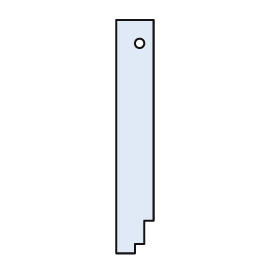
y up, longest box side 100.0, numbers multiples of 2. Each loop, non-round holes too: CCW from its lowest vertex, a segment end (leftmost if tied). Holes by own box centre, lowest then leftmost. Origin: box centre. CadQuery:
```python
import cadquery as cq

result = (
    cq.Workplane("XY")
    .moveTo(-8.0, -50.0)
    .lineTo(0.0, -50.0)
    .lineTo(0.0, -46.0)
    .lineTo(4.0, -46.0)
    .lineTo(4.0, -36.0)
    .lineTo(8.0, -36.0)
    .lineTo(8.0, 50.0)
    .lineTo(-8.0, 50.0)
    .close()
    .moveTo(2.0, 40.0)
    .circle(2.0)
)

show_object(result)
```